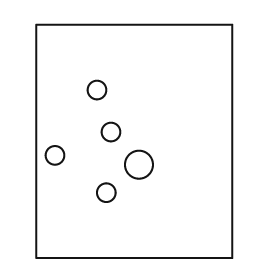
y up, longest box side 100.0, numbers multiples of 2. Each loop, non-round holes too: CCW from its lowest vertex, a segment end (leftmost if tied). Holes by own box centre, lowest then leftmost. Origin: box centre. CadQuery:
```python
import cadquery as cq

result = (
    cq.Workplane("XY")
    .moveTo(-42.0, -50.0)
    .lineTo(42.0, -50.0)
    .lineTo(42.0, 50.0)
    .lineTo(-42.0, 50.0)
    .close()
    .moveTo(-12.0, -22.0)
    .circle(4.0)
    .moveTo(2.0, -10.0)
    .circle(6.0)
    .moveTo(-34.0, -6.0)
    .circle(4.0)
    .moveTo(-10.0, 4.0)
    .circle(4.0)
    .moveTo(-16.0, 22.0)
    .circle(4.0)
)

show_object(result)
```